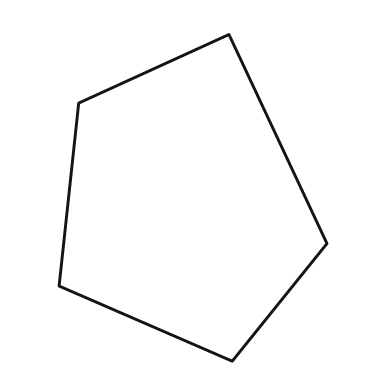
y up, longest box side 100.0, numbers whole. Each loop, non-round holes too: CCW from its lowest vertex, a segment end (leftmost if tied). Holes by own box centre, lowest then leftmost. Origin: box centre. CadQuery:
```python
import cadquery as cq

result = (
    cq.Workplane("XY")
    .moveTo(12.0, -50.0)
    .lineTo(41.0, -14.0)
    .lineTo(11.0, 50.0)
    .lineTo(-35.0, 29.0)
    .lineTo(-41.0, -27.0)
    .close()
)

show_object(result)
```